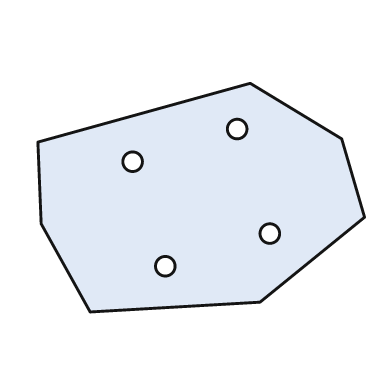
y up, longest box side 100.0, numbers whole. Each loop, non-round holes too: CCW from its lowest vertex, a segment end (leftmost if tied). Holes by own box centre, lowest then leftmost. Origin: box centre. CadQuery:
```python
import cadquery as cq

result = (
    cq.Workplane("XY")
    .moveTo(-34.0, -35.0)
    .lineTo(18.0, -32.0)
    .lineTo(50.0, -6.0)
    .lineTo(43.0, 18.0)
    .lineTo(15.0, 35.0)
    .lineTo(-50.0, 17.0)
    .lineTo(-49.0, -8.0)
    .close()
    .moveTo(-11.0, -21.0)
    .circle(3.0)
    .moveTo(21.0, -11.0)
    .circle(3.0)
    .moveTo(-21.0, 11.0)
    .circle(3.0)
    .moveTo(11.0, 21.0)
    .circle(3.0)
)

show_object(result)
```